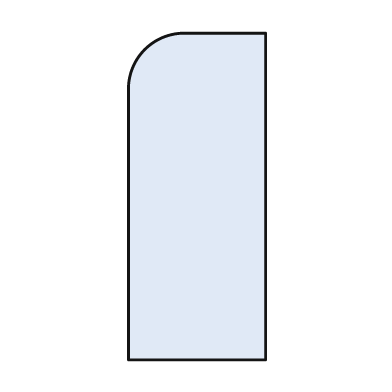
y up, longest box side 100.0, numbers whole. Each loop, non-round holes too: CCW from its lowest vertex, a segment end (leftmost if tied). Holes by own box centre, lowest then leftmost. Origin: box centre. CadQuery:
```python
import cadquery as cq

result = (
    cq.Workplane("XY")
    .moveTo(-21.0, -50.0)
    .lineTo(21.0, -50.0)
    .lineTo(21.0, 50.0)
    .lineTo(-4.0, 50.0)
    .threePointArc((-16.0, 45.0), (-21.0, 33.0))
    .close()
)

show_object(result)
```